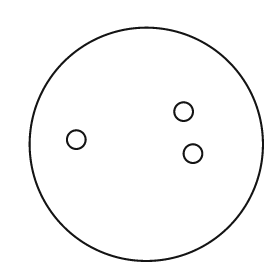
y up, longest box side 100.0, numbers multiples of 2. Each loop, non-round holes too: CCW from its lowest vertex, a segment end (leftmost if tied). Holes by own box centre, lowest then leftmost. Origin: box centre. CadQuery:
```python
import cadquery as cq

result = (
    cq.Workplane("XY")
    .moveTo(0.0, 0.0)
    .circle(50.0)
    .moveTo(20.0, -4.0)
    .circle(4.0)
    .moveTo(-30.0, 2.0)
    .circle(4.0)
    .moveTo(16.0, 14.0)
    .circle(4.0)
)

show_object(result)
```